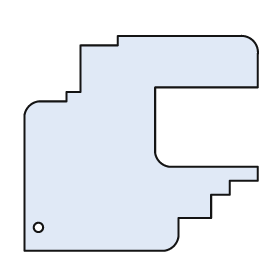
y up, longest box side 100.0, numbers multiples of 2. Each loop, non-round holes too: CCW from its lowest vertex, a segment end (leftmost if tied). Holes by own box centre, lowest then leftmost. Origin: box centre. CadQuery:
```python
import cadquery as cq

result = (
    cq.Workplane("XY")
    .moveTo(-50.0, -46.0)
    .lineTo(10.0, -46.0)
    .threePointArc((14.0, -44.0), (16.0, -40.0))
    .lineTo(16.0, -32.0)
    .lineTo(30.0, -32.0)
    .lineTo(30.0, -22.0)
    .lineTo(38.0, -22.0)
    .lineTo(38.0, -16.0)
    .lineTo(50.0, -16.0)
    .lineTo(50.0, -10.0)
    .lineTo(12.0, -10.0)
    .threePointArc((8.0, -8.0), (6.0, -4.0))
    .lineTo(6.0, 24.0)
    .lineTo(50.0, 24.0)
    .lineTo(50.0, 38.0)
    .threePointArc((48.0, 44.0), (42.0, 46.0))
    .lineTo(-10.0, 46.0)
    .lineTo(-10.0, 42.0)
    .lineTo(-26.0, 42.0)
    .lineTo(-26.0, 22.0)
    .lineTo(-32.0, 22.0)
    .lineTo(-32.0, 18.0)
    .lineTo(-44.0, 18.0)
    .threePointArc((-48.0, 16.0), (-50.0, 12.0))
    .close()
    .moveTo(-44.0, -36.0)
    .circle(2.0)
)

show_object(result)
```